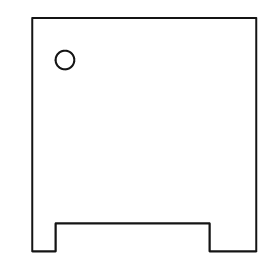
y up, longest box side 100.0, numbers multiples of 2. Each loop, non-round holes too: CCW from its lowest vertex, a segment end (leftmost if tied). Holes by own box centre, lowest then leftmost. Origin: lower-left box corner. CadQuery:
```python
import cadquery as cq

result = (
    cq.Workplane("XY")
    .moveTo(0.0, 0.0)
    .lineTo(10.0, 0.0)
    .lineTo(10.0, 12.0)
    .lineTo(76.0, 12.0)
    .lineTo(76.0, 0.0)
    .lineTo(96.0, 0.0)
    .lineTo(96.0, 100.0)
    .lineTo(0.0, 100.0)
    .close()
    .moveTo(14.0, 82.0)
    .circle(4.0)
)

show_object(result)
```